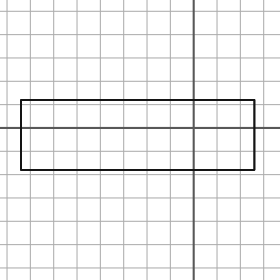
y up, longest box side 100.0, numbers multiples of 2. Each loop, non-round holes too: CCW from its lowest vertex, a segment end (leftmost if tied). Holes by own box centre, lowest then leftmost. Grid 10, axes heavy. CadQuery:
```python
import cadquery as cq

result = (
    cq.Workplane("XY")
    .moveTo(-74.0, -18.0)
    .lineTo(26.0, -18.0)
    .lineTo(26.0, 12.0)
    .lineTo(-74.0, 12.0)
    .close()
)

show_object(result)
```